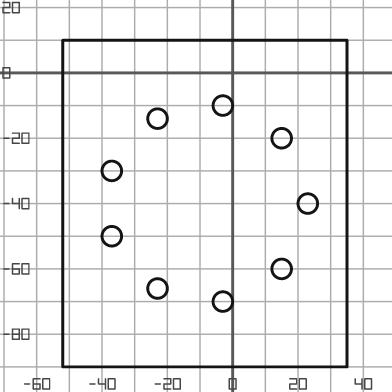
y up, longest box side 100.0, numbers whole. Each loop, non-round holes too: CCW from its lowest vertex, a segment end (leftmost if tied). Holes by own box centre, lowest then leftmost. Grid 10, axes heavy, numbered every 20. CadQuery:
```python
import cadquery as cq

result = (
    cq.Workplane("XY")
    .moveTo(-52.0, -90.0)
    .lineTo(35.0, -90.0)
    .lineTo(35.0, 10.0)
    .lineTo(-52.0, 10.0)
    .close()
    .moveTo(-3.0, -70.0)
    .circle(3.0)
    .moveTo(-23.0, -66.0)
    .circle(3.0)
    .moveTo(15.0, -60.0)
    .circle(3.0)
    .moveTo(-37.0, -50.0)
    .circle(3.0)
    .moveTo(23.0, -40.0)
    .circle(3.0)
    .moveTo(-37.0, -30.0)
    .circle(3.0)
    .moveTo(15.0, -20.0)
    .circle(3.0)
    .moveTo(-23.0, -14.0)
    .circle(3.0)
    .moveTo(-3.0, -10.0)
    .circle(3.0)
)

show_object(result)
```